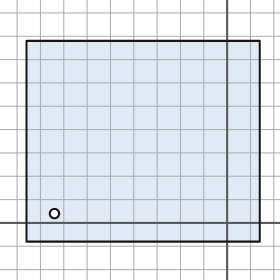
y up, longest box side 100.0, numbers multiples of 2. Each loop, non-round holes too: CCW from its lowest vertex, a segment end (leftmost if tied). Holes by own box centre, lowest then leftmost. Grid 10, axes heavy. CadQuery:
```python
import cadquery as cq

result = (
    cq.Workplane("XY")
    .moveTo(-86.0, -8.0)
    .lineTo(14.0, -8.0)
    .lineTo(14.0, 78.0)
    .lineTo(-86.0, 78.0)
    .close()
    .moveTo(-74.0, 4.0)
    .circle(2.0)
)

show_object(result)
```